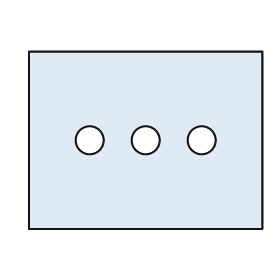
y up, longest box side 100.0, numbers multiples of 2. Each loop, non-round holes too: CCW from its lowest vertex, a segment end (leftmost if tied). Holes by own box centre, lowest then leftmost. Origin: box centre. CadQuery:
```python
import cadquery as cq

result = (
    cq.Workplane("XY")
    .moveTo(-50.0, -38.0)
    .lineTo(50.0, -38.0)
    .lineTo(50.0, 38.0)
    .lineTo(-50.0, 38.0)
    .close()
    .moveTo(-24.0, 0.0)
    .circle(6.0)
    .moveTo(0.0, 0.0)
    .circle(6.0)
    .moveTo(24.0, 0.0)
    .circle(6.0)
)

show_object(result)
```